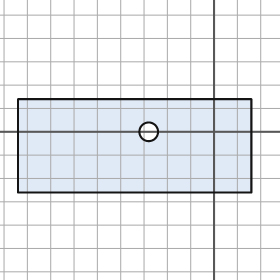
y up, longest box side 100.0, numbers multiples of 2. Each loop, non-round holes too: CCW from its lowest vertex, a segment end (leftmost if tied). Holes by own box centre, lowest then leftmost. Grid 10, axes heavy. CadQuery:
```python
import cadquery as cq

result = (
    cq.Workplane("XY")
    .moveTo(-84.0, -26.0)
    .lineTo(16.0, -26.0)
    .lineTo(16.0, 14.0)
    .lineTo(-84.0, 14.0)
    .close()
    .moveTo(-28.0, 0.0)
    .circle(4.0)
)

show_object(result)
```